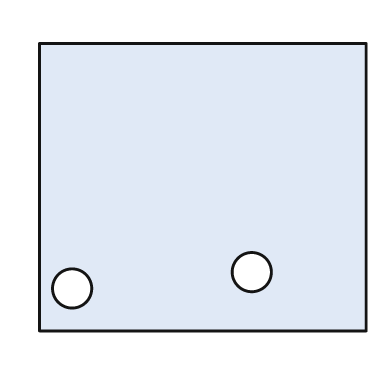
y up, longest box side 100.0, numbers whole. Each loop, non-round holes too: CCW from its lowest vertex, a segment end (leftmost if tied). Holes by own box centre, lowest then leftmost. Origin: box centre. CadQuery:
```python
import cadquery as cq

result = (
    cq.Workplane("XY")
    .moveTo(-50.0, -44.0)
    .lineTo(50.0, -44.0)
    .lineTo(50.0, 44.0)
    .lineTo(-50.0, 44.0)
    .close()
    .moveTo(-40.0, -31.0)
    .circle(6.0)
    .moveTo(15.0, -26.0)
    .circle(6.0)
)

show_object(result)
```